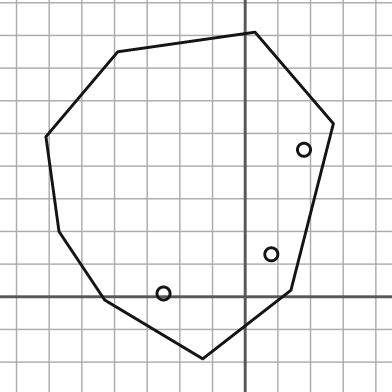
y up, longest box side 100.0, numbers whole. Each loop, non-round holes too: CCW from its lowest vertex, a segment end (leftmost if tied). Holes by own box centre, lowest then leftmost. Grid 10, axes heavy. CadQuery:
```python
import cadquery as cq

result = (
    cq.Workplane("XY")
    .moveTo(-13.0, -19.0)
    .lineTo(14.0, 2.0)
    .lineTo(27.0, 53.0)
    .lineTo(3.0, 81.0)
    .lineTo(-39.0, 75.0)
    .lineTo(-61.0, 49.0)
    .lineTo(-57.0, 20.0)
    .lineTo(-43.0, -1.0)
    .close()
    .moveTo(-25.0, 1.0)
    .circle(2.0)
    .moveTo(8.0, 13.0)
    .circle(2.0)
    .moveTo(18.0, 45.0)
    .circle(2.0)
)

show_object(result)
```